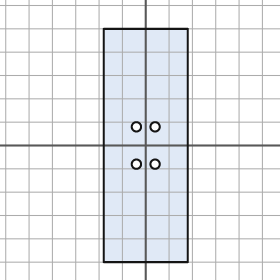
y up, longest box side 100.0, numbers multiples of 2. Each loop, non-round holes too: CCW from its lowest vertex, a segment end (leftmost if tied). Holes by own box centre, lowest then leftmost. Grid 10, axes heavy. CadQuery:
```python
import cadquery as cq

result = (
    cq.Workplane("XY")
    .moveTo(-18.0, -50.0)
    .lineTo(18.0, -50.0)
    .lineTo(18.0, 50.0)
    .lineTo(-18.0, 50.0)
    .close()
    .moveTo(-4.0, -8.0)
    .circle(2.0)
    .moveTo(4.0, -8.0)
    .circle(2.0)
    .moveTo(-4.0, 8.0)
    .circle(2.0)
    .moveTo(4.0, 8.0)
    .circle(2.0)
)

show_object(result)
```